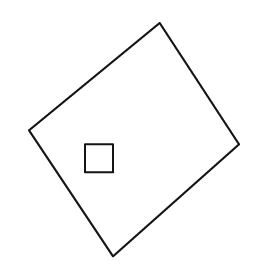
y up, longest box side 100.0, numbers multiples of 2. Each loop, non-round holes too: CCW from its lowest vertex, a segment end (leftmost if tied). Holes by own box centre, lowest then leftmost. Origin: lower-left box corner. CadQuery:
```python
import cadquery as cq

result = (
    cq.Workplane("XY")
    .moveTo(36.0, 0.0)
    .lineTo(90.0, 48.0)
    .lineTo(56.0, 100.0)
    .lineTo(0.0, 54.0)
    .close()
    .moveTo(24.0, 36.0)
    .lineTo(36.0, 36.0)
    .lineTo(36.0, 48.0)
    .lineTo(24.0, 48.0)
    .close()
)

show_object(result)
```